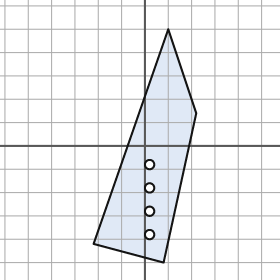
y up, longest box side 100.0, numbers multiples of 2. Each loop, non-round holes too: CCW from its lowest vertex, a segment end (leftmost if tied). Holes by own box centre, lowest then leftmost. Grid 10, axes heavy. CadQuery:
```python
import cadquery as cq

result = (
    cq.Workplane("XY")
    .moveTo(8.0, -50.0)
    .lineTo(22.0, 14.0)
    .lineTo(10.0, 50.0)
    .lineTo(-22.0, -42.0)
    .close()
    .moveTo(2.0, -38.0)
    .circle(2.0)
    .moveTo(2.0, -28.0)
    .circle(2.0)
    .moveTo(2.0, -18.0)
    .circle(2.0)
    .moveTo(2.0, -8.0)
    .circle(2.0)
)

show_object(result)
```